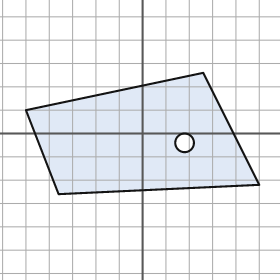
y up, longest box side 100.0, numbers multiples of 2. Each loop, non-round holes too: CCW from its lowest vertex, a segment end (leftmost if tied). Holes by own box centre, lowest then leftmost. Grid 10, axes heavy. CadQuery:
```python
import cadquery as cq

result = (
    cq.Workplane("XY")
    .moveTo(-36.0, -26.0)
    .lineTo(50.0, -22.0)
    .lineTo(26.0, 26.0)
    .lineTo(-50.0, 10.0)
    .close()
    .moveTo(18.0, -4.0)
    .circle(4.0)
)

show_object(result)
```